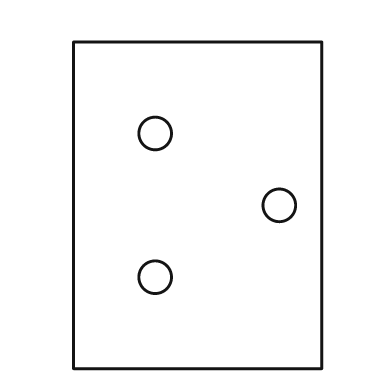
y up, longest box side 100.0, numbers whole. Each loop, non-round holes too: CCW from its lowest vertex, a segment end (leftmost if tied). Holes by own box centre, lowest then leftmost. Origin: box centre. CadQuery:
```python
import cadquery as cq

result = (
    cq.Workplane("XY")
    .moveTo(-38.0, -50.0)
    .lineTo(38.0, -50.0)
    .lineTo(38.0, 50.0)
    .lineTo(-38.0, 50.0)
    .close()
    .moveTo(-13.0, -22.0)
    .circle(5.0)
    .moveTo(25.0, 0.0)
    .circle(5.0)
    .moveTo(-13.0, 22.0)
    .circle(5.0)
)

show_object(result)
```